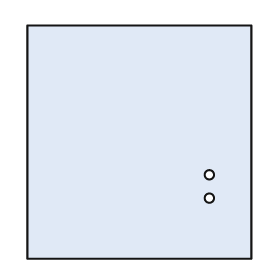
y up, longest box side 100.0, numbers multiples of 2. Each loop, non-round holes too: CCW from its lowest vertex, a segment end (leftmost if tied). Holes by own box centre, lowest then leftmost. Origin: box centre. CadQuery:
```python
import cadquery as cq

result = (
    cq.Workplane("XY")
    .moveTo(-48.0, -50.0)
    .lineTo(48.0, -50.0)
    .lineTo(48.0, 50.0)
    .lineTo(-48.0, 50.0)
    .close()
    .moveTo(30.0, -24.0)
    .circle(2.0)
    .moveTo(30.0, -14.0)
    .circle(2.0)
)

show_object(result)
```